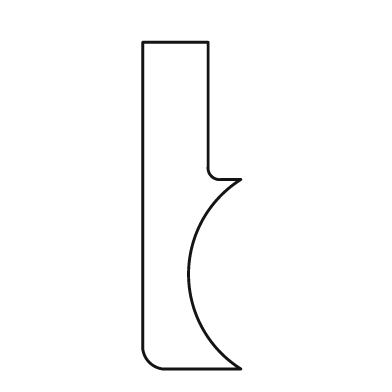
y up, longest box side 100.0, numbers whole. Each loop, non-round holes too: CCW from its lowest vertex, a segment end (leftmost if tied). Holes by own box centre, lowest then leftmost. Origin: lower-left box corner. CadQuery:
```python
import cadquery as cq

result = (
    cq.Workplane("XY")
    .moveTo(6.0, 0.0)
    .lineTo(30.0, 0.0)
    .threePointArc((14.0, 29.0), (30.0, 58.0))
    .lineTo(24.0, 58.0)
    .threePointArc((21.0, 59.0), (20.0, 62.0))
    .lineTo(20.0, 100.0)
    .lineTo(0.0, 100.0)
    .lineTo(0.0, 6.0)
    .threePointArc((2.0, 2.0), (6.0, 0.0))
    .close()
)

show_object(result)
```